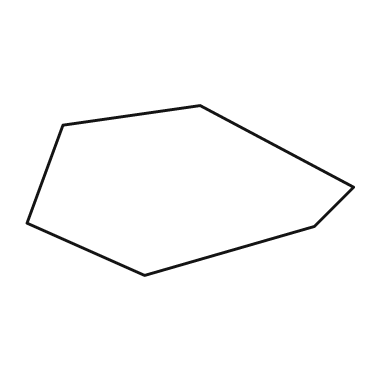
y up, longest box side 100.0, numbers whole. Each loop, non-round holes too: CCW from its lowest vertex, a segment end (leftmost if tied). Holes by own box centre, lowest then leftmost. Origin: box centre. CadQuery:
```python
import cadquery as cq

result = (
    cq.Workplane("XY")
    .moveTo(-14.0, -26.0)
    .lineTo(38.0, -11.0)
    .lineTo(50.0, 1.0)
    .lineTo(3.0, 26.0)
    .lineTo(-39.0, 20.0)
    .lineTo(-50.0, -10.0)
    .close()
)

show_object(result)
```